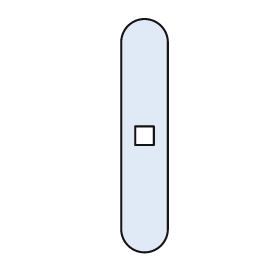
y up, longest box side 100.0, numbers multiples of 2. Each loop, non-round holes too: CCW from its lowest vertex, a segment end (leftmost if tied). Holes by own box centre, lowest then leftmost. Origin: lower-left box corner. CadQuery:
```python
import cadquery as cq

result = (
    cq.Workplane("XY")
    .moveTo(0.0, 10.0)
    .threePointArc((10.0, 0.0), (20.0, 10.0))
    .lineTo(20.0, 90.0)
    .threePointArc((10.0, 100.0), (0.0, 90.0))
    .close()
    .moveTo(6.0, 46.0)
    .lineTo(14.0, 46.0)
    .lineTo(14.0, 54.0)
    .lineTo(6.0, 54.0)
    .close()
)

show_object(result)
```